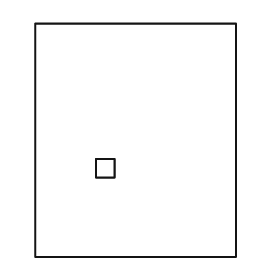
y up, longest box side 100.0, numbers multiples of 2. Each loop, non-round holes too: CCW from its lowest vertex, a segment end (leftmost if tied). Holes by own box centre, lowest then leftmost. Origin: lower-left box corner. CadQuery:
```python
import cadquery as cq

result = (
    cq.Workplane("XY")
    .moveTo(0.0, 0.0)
    .lineTo(86.0, 0.0)
    .lineTo(86.0, 100.0)
    .lineTo(0.0, 100.0)
    .close()
    .moveTo(26.0, 34.0)
    .lineTo(34.0, 34.0)
    .lineTo(34.0, 42.0)
    .lineTo(26.0, 42.0)
    .close()
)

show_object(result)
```